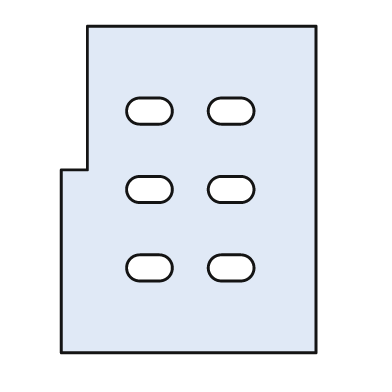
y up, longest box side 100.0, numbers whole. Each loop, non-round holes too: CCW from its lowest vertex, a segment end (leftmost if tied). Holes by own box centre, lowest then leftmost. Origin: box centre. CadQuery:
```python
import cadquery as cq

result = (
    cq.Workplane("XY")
    .moveTo(-39.0, -50.0)
    .lineTo(39.0, -50.0)
    .lineTo(39.0, 50.0)
    .lineTo(-31.0, 50.0)
    .lineTo(-31.0, 6.0)
    .lineTo(-39.0, 6.0)
    .close()
    .moveTo(-15.0, -28.0)
    .lineTo(-9.0, -28.0)
    .threePointArc((-5.0, -24.0), (-9.0, -20.0))
    .lineTo(-15.0, -20.0)
    .threePointArc((-19.0, -24.0), (-15.0, -28.0))
    .close()
    .moveTo(10.0, -28.0)
    .lineTo(16.0, -28.0)
    .threePointArc((20.0, -24.0), (16.0, -20.0))
    .lineTo(10.0, -20.0)
    .threePointArc((6.0, -24.0), (10.0, -28.0))
    .close()
    .moveTo(-15.0, -4.0)
    .lineTo(-9.0, -4.0)
    .threePointArc((-5.0, 0.0), (-9.0, 4.0))
    .lineTo(-15.0, 4.0)
    .threePointArc((-19.0, 0.0), (-15.0, -4.0))
    .close()
    .moveTo(10.0, -4.0)
    .lineTo(16.0, -4.0)
    .threePointArc((20.0, 0.0), (16.0, 4.0))
    .lineTo(10.0, 4.0)
    .threePointArc((6.0, 0.0), (10.0, -4.0))
    .close()
    .moveTo(-15.0, 20.0)
    .lineTo(-9.0, 20.0)
    .threePointArc((-5.0, 24.0), (-9.0, 28.0))
    .lineTo(-15.0, 28.0)
    .threePointArc((-19.0, 24.0), (-15.0, 20.0))
    .close()
    .moveTo(10.0, 20.0)
    .lineTo(16.0, 20.0)
    .threePointArc((20.0, 24.0), (16.0, 28.0))
    .lineTo(10.0, 28.0)
    .threePointArc((6.0, 24.0), (10.0, 20.0))
    .close()
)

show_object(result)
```